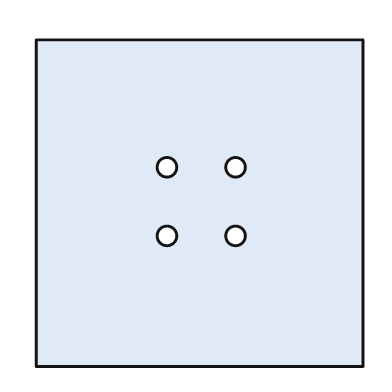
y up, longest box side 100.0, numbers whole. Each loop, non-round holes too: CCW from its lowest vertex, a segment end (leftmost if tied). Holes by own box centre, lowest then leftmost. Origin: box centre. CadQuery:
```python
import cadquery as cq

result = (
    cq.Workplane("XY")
    .moveTo(-50.0, -50.0)
    .lineTo(50.0, -50.0)
    .lineTo(50.0, 50.0)
    .lineTo(-50.0, 50.0)
    .close()
    .moveTo(-10.0, -10.0)
    .circle(3.0)
    .moveTo(11.0, -10.0)
    .circle(3.0)
    .moveTo(-10.0, 11.0)
    .circle(3.0)
    .moveTo(11.0, 11.0)
    .circle(3.0)
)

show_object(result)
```